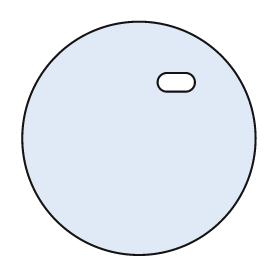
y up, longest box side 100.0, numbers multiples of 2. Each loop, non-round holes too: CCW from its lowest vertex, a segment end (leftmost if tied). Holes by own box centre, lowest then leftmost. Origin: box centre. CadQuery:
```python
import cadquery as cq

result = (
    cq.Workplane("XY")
    .moveTo(0.0, 0.0)
    .circle(50.0)
    .moveTo(12.0, 20.0)
    .lineTo(20.0, 20.0)
    .threePointArc((24.0, 24.0), (20.0, 28.0))
    .lineTo(12.0, 28.0)
    .threePointArc((8.0, 24.0), (12.0, 20.0))
    .close()
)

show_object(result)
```